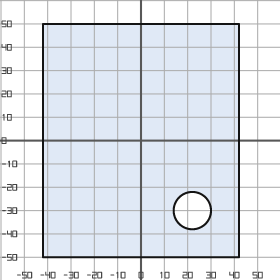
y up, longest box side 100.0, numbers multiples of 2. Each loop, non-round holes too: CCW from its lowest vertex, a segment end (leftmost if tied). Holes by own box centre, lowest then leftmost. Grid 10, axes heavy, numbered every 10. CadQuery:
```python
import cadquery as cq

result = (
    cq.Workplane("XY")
    .moveTo(-42.0, -50.0)
    .lineTo(42.0, -50.0)
    .lineTo(42.0, 50.0)
    .lineTo(-42.0, 50.0)
    .close()
    .moveTo(22.0, -30.0)
    .circle(8.0)
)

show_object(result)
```